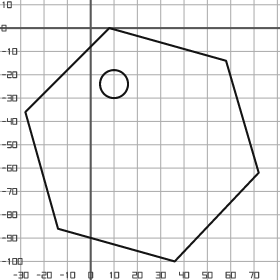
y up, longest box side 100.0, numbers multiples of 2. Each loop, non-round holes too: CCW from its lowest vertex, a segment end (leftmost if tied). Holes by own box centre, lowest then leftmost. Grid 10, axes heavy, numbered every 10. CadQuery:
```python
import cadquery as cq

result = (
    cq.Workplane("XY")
    .moveTo(36.0, -100.0)
    .lineTo(72.0, -62.0)
    .lineTo(58.0, -14.0)
    .lineTo(8.0, 0.0)
    .lineTo(-28.0, -36.0)
    .lineTo(-14.0, -86.0)
    .close()
    .moveTo(10.0, -24.0)
    .circle(6.0)
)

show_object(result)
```